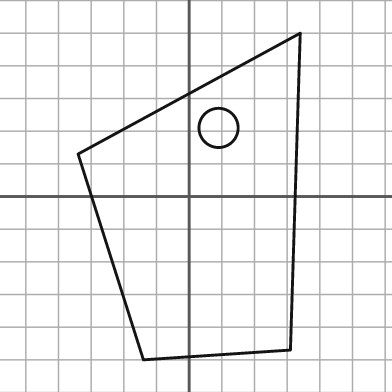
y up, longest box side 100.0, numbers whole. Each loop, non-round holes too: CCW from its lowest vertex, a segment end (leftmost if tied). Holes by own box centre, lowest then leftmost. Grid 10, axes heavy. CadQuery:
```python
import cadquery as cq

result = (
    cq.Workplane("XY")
    .moveTo(-14.0, -50.0)
    .lineTo(31.0, -47.0)
    .lineTo(34.0, 50.0)
    .lineTo(-34.0, 13.0)
    .close()
    .moveTo(9.0, 21.0)
    .circle(6.0)
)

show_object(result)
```